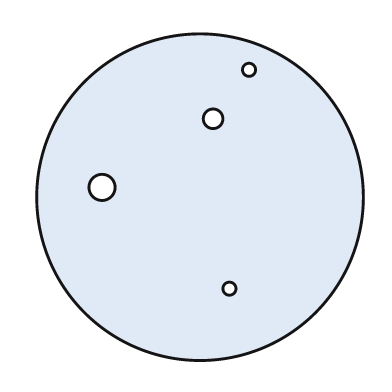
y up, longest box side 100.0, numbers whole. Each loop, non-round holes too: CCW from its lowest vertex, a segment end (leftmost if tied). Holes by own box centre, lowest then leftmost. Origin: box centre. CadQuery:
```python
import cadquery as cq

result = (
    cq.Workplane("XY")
    .moveTo(0.0, 0.0)
    .circle(50.0)
    .moveTo(9.0, -28.0)
    .circle(2.0)
    .moveTo(-30.0, 3.0)
    .circle(4.0)
    .moveTo(4.0, 24.0)
    .circle(3.0)
    .moveTo(15.0, 39.0)
    .circle(2.0)
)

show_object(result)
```